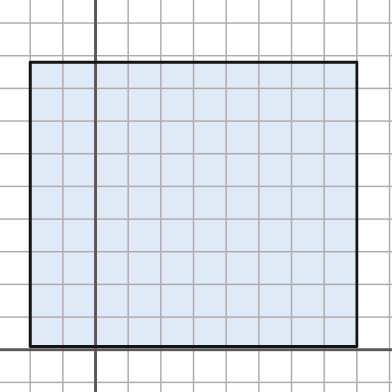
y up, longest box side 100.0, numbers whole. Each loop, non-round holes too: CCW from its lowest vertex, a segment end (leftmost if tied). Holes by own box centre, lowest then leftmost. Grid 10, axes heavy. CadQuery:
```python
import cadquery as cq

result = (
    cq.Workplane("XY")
    .moveTo(-20.0, 1.0)
    .lineTo(80.0, 1.0)
    .lineTo(80.0, 88.0)
    .lineTo(-20.0, 88.0)
    .close()
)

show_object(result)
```